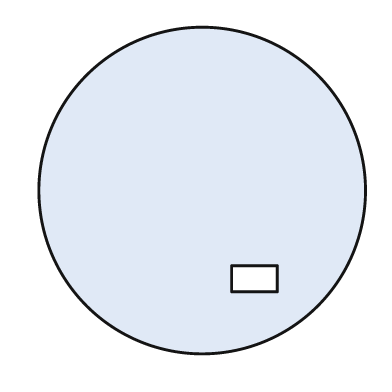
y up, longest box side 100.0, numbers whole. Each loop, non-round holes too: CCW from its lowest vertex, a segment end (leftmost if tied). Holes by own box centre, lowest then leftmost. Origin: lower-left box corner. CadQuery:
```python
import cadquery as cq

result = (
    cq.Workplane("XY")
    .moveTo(50.0, 50.0)
    .circle(50.0)
    .moveTo(59.0, 19.0)
    .lineTo(73.0, 19.0)
    .lineTo(73.0, 27.0)
    .lineTo(59.0, 27.0)
    .close()
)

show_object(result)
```